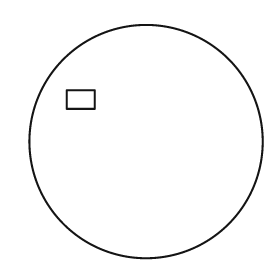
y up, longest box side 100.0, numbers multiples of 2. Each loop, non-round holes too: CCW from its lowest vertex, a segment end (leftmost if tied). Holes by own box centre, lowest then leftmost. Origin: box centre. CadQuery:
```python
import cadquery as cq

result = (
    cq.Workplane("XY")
    .moveTo(0.0, 0.0)
    .circle(50.0)
    .moveTo(-34.0, 14.0)
    .lineTo(-22.0, 14.0)
    .lineTo(-22.0, 22.0)
    .lineTo(-34.0, 22.0)
    .close()
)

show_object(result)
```